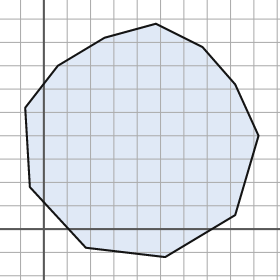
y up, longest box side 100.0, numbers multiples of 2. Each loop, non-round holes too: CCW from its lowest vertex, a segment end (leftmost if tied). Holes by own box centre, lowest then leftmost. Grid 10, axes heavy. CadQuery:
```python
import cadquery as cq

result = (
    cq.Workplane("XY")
    .moveTo(52.0, -12.0)
    .lineTo(82.0, 6.0)
    .lineTo(92.0, 40.0)
    .lineTo(82.0, 62.0)
    .lineTo(68.0, 78.0)
    .lineTo(48.0, 88.0)
    .lineTo(26.0, 82.0)
    .lineTo(6.0, 70.0)
    .lineTo(-8.0, 52.0)
    .lineTo(-6.0, 18.0)
    .lineTo(18.0, -8.0)
    .close()
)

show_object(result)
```